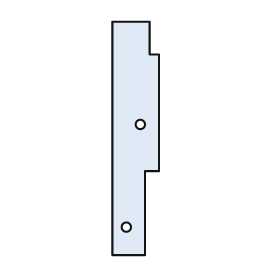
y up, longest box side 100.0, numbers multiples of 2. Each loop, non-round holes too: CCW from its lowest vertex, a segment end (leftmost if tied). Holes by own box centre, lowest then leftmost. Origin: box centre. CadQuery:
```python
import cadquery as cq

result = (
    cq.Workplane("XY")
    .moveTo(-10.0, -50.0)
    .lineTo(4.0, -50.0)
    .lineTo(4.0, -14.0)
    .lineTo(10.0, -14.0)
    .lineTo(10.0, 36.0)
    .lineTo(6.0, 36.0)
    .lineTo(6.0, 50.0)
    .lineTo(-10.0, 50.0)
    .close()
    .moveTo(-4.0, -38.0)
    .circle(2.0)
    .moveTo(2.0, 6.0)
    .circle(2.0)
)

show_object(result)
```